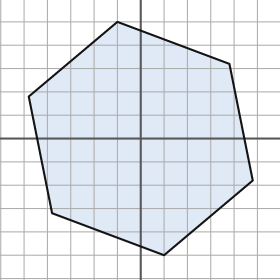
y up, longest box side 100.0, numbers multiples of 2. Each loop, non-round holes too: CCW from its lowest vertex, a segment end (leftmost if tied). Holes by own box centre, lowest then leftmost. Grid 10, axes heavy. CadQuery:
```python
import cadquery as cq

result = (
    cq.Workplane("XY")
    .moveTo(10.0, -50.0)
    .lineTo(48.0, -18.0)
    .lineTo(38.0, 32.0)
    .lineTo(-10.0, 50.0)
    .lineTo(-48.0, 18.0)
    .lineTo(-38.0, -32.0)
    .close()
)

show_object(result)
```